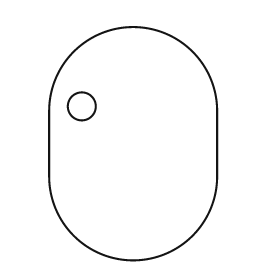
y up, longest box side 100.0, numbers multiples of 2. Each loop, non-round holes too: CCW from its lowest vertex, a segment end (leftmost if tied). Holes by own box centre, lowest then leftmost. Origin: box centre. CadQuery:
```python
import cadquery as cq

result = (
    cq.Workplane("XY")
    .moveTo(-36.0, -14.0)
    .threePointArc((0.0, -50.0), (36.0, -14.0))
    .lineTo(36.0, 14.0)
    .threePointArc((0.0, 50.0), (-36.0, 14.0))
    .close()
    .moveTo(-22.0, 16.0)
    .circle(6.0)
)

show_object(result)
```